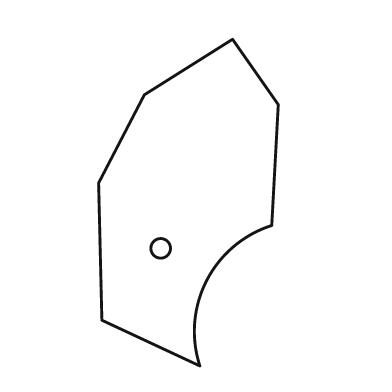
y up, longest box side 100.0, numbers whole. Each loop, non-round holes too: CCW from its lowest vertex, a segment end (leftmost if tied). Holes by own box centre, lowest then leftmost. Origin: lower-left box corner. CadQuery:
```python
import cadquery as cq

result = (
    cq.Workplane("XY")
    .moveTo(31.0, 0.0)
    .threePointArc((33.0, 26.0), (53.0, 43.0))
    .lineTo(55.0, 80.0)
    .lineTo(41.0, 100.0)
    .lineTo(14.0, 83.0)
    .lineTo(0.0, 56.0)
    .lineTo(1.0, 14.0)
    .close()
    .moveTo(19.0, 36.0)
    .circle(3.0)
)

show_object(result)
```